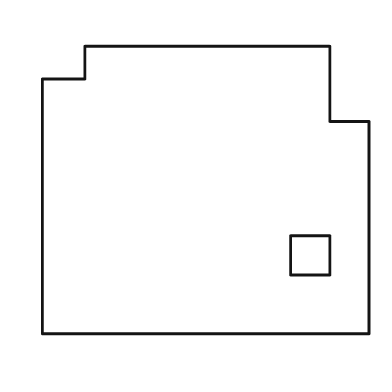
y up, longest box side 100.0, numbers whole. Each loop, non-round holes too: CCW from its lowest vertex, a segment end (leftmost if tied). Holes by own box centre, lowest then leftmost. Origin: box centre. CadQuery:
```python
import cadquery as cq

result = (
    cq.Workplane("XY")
    .moveTo(-50.0, -44.0)
    .lineTo(50.0, -44.0)
    .lineTo(50.0, 21.0)
    .lineTo(38.0, 21.0)
    .lineTo(38.0, 44.0)
    .lineTo(-37.0, 44.0)
    .lineTo(-37.0, 34.0)
    .lineTo(-50.0, 34.0)
    .close()
    .moveTo(26.0, -26.0)
    .lineTo(38.0, -26.0)
    .lineTo(38.0, -14.0)
    .lineTo(26.0, -14.0)
    .close()
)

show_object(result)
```